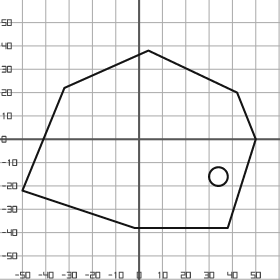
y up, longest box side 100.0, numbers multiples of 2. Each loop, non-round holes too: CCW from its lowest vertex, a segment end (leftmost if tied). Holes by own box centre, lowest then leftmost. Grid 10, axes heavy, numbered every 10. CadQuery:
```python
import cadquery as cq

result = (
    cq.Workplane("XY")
    .moveTo(-2.0, -38.0)
    .lineTo(38.0, -38.0)
    .lineTo(50.0, 0.0)
    .lineTo(42.0, 20.0)
    .lineTo(4.0, 38.0)
    .lineTo(-32.0, 22.0)
    .lineTo(-50.0, -22.0)
    .close()
    .moveTo(34.0, -16.0)
    .circle(4.0)
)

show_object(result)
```